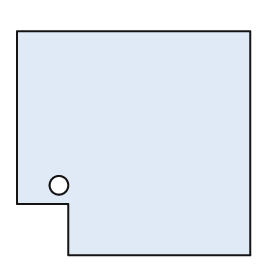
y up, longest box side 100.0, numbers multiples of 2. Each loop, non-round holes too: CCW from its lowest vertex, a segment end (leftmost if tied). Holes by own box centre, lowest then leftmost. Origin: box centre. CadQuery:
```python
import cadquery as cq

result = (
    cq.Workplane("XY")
    .moveTo(-28.0, -48.0)
    .lineTo(50.0, -48.0)
    .lineTo(50.0, 48.0)
    .lineTo(-50.0, 48.0)
    .lineTo(-50.0, -26.0)
    .lineTo(-28.0, -26.0)
    .close()
    .moveTo(-32.0, -18.0)
    .circle(4.0)
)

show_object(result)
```